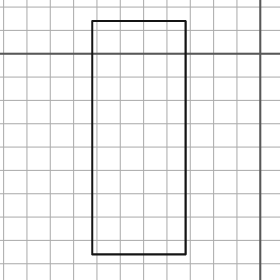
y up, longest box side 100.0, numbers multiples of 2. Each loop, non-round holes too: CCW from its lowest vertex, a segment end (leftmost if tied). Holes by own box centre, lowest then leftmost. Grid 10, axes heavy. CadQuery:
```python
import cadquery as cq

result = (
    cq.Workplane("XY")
    .moveTo(-72.0, -86.0)
    .lineTo(-32.0, -86.0)
    .lineTo(-32.0, 14.0)
    .lineTo(-72.0, 14.0)
    .close()
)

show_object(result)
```